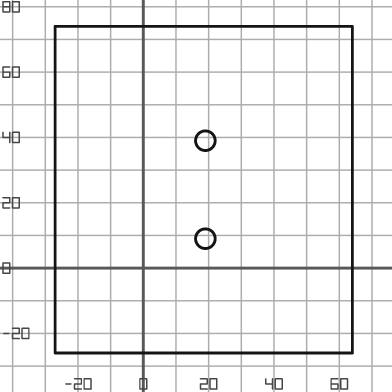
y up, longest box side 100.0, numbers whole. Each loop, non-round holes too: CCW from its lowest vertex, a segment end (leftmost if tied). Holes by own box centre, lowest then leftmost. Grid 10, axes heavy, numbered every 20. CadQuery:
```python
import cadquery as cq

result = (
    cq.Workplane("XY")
    .moveTo(-27.0, -26.0)
    .lineTo(64.0, -26.0)
    .lineTo(64.0, 74.0)
    .lineTo(-27.0, 74.0)
    .close()
    .moveTo(19.0, 9.0)
    .circle(3.0)
    .moveTo(19.0, 39.0)
    .circle(3.0)
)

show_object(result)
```